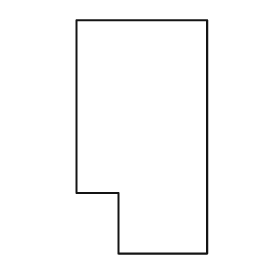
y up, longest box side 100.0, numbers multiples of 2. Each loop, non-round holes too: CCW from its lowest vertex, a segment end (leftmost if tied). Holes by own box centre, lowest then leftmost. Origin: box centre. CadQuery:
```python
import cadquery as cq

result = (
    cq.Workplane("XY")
    .moveTo(-10.0, -50.0)
    .lineTo(28.0, -50.0)
    .lineTo(28.0, 50.0)
    .lineTo(-28.0, 50.0)
    .lineTo(-28.0, -24.0)
    .lineTo(-10.0, -24.0)
    .close()
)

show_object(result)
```